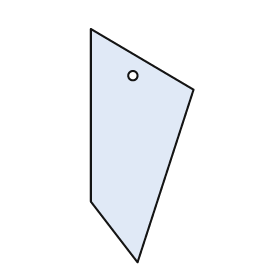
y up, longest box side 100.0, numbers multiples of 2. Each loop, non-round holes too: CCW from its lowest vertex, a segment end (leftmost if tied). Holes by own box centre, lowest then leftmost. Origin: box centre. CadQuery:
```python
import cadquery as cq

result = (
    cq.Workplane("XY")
    .moveTo(-2.0, -50.0)
    .lineTo(22.0, 24.0)
    .lineTo(-22.0, 50.0)
    .lineTo(-22.0, -24.0)
    .close()
    .moveTo(-4.0, 30.0)
    .circle(2.0)
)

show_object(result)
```